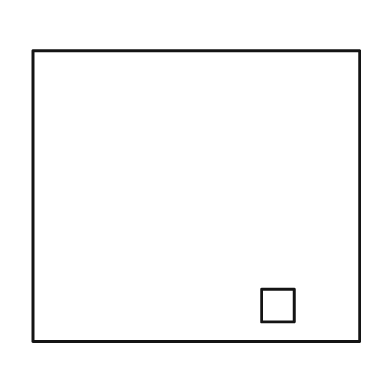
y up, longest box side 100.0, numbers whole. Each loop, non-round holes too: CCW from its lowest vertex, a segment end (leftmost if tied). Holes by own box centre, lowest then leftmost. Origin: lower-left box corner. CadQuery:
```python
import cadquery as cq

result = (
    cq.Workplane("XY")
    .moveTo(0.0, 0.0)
    .lineTo(100.0, 0.0)
    .lineTo(100.0, 89.0)
    .lineTo(0.0, 89.0)
    .close()
    .moveTo(70.0, 6.0)
    .lineTo(80.0, 6.0)
    .lineTo(80.0, 16.0)
    .lineTo(70.0, 16.0)
    .close()
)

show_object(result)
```